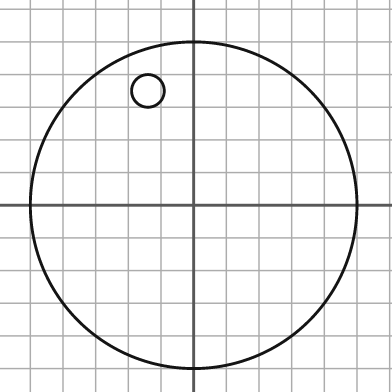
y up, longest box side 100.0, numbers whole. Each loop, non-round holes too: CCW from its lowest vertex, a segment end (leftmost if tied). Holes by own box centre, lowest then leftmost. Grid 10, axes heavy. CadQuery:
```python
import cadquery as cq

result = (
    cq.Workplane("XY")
    .moveTo(0.0, 0.0)
    .circle(50.0)
    .moveTo(-14.0, 35.0)
    .circle(5.0)
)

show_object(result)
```